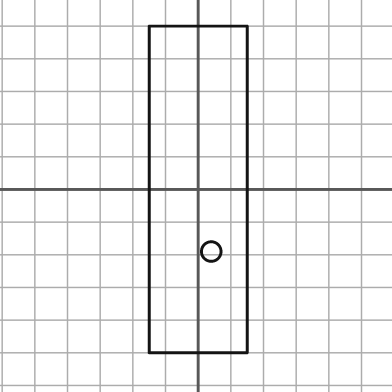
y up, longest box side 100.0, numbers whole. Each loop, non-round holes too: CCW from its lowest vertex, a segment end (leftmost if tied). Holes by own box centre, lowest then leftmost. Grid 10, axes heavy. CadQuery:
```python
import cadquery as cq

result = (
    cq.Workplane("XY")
    .moveTo(-15.0, -50.0)
    .lineTo(15.0, -50.0)
    .lineTo(15.0, 50.0)
    .lineTo(-15.0, 50.0)
    .close()
    .moveTo(4.0, -19.0)
    .circle(3.0)
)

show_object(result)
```